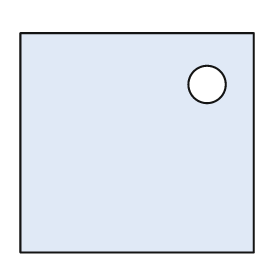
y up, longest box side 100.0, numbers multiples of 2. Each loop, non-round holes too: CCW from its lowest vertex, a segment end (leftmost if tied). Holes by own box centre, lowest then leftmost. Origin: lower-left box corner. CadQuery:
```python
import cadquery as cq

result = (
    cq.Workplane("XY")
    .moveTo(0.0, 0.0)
    .lineTo(100.0, 0.0)
    .lineTo(100.0, 94.0)
    .lineTo(0.0, 94.0)
    .close()
    .moveTo(80.0, 72.0)
    .circle(8.0)
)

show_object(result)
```